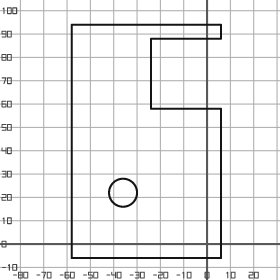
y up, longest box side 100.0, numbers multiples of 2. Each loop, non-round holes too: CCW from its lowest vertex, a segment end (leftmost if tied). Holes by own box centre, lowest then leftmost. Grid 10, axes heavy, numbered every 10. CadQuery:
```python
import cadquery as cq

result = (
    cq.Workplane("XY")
    .moveTo(-58.0, -6.0)
    .lineTo(6.0, -6.0)
    .lineTo(6.0, 58.0)
    .lineTo(-24.0, 58.0)
    .lineTo(-24.0, 88.0)
    .lineTo(6.0, 88.0)
    .lineTo(6.0, 94.0)
    .lineTo(-58.0, 94.0)
    .close()
    .moveTo(-36.0, 22.0)
    .circle(6.0)
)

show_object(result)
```